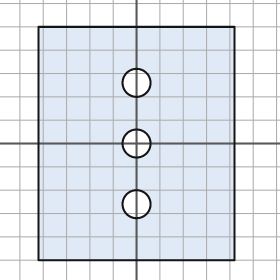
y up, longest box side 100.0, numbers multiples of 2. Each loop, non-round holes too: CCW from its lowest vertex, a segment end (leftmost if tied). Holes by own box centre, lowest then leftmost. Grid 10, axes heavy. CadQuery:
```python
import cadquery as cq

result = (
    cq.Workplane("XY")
    .moveTo(-42.0, -50.0)
    .lineTo(42.0, -50.0)
    .lineTo(42.0, 50.0)
    .lineTo(-42.0, 50.0)
    .close()
    .moveTo(0.0, -26.0)
    .circle(6.0)
    .moveTo(0.0, 0.0)
    .circle(6.0)
    .moveTo(0.0, 26.0)
    .circle(6.0)
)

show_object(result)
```